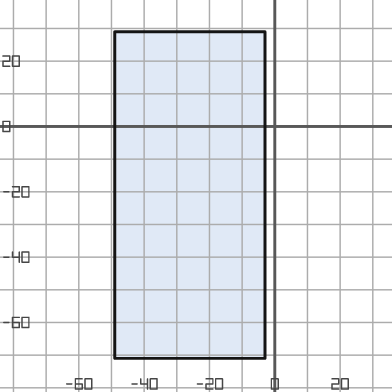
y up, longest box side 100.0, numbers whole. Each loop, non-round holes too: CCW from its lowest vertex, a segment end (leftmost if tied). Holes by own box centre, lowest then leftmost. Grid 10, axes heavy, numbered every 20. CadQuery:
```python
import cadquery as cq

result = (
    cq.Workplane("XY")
    .moveTo(-49.0, -71.0)
    .lineTo(-3.0, -71.0)
    .lineTo(-3.0, 29.0)
    .lineTo(-49.0, 29.0)
    .close()
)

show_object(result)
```